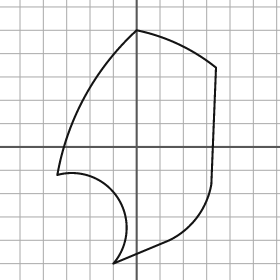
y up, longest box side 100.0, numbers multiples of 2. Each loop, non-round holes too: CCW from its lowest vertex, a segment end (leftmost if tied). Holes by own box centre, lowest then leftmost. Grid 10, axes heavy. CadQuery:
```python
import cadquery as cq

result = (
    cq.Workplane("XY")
    .moveTo(-10.0, -50.0)
    .lineTo(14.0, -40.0)
    .threePointArc((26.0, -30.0), (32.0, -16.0))
    .lineTo(34.0, 34.0)
    .threePointArc((18.0, 44.0), (0.0, 50.0))
    .threePointArc((-22.0, 22.0), (-34.0, -12.0))
    .threePointArc((-8.0, -22.0), (-10.0, -50.0))
    .close()
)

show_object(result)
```